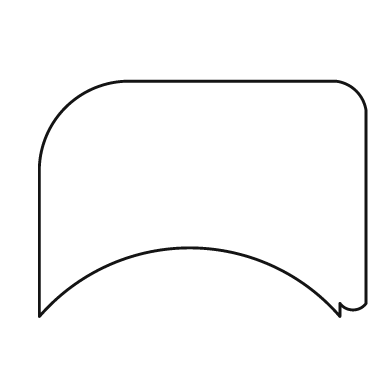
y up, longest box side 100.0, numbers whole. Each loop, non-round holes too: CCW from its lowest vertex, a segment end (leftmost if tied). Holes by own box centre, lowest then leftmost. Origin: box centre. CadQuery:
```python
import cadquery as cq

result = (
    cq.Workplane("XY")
    .moveTo(-50.0, -36.0)
    .threePointArc((-4.0, -15.0), (42.0, -36.0))
    .lineTo(42.0, -32.0)
    .threePointArc((46.0, -34.0), (50.0, -32.0))
    .lineTo(50.0, 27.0)
    .threePointArc((47.0, 33.0), (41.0, 36.0))
    .lineTo(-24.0, 36.0)
    .threePointArc((-42.0, 28.0), (-50.0, 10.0))
    .close()
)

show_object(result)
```